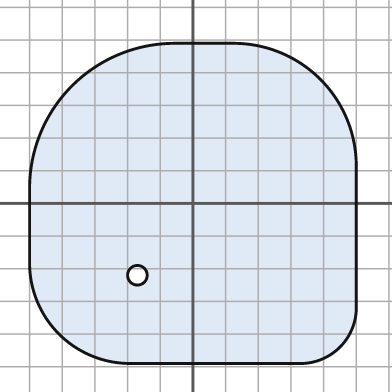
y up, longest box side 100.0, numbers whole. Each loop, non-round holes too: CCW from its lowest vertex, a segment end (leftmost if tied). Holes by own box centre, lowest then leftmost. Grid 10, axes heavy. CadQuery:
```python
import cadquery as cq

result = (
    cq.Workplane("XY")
    .moveTo(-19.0, -49.0)
    .lineTo(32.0, -49.0)
    .threePointArc((45.0, -44.0), (50.0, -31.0))
    .lineTo(50.0, 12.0)
    .threePointArc((39.0, 38.0), (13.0, 49.0))
    .lineTo(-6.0, 49.0)
    .threePointArc((-37.0, 36.0), (-50.0, 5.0))
    .lineTo(-50.0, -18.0)
    .threePointArc((-41.0, -40.0), (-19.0, -49.0))
    .close()
    .moveTo(-17.0, -22.0)
    .circle(3.0)
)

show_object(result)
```